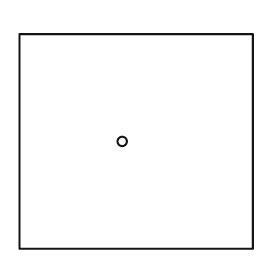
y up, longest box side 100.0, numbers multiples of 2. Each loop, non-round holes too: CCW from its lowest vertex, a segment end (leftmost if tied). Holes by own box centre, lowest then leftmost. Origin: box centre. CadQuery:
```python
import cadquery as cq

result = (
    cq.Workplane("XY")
    .moveTo(-50.0, -46.0)
    .lineTo(50.0, -46.0)
    .lineTo(50.0, 46.0)
    .lineTo(-50.0, 46.0)
    .close()
    .moveTo(-6.0, 0.0)
    .circle(2.0)
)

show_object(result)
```